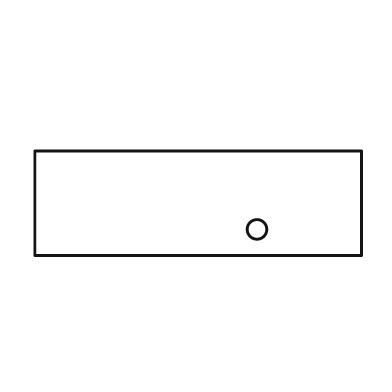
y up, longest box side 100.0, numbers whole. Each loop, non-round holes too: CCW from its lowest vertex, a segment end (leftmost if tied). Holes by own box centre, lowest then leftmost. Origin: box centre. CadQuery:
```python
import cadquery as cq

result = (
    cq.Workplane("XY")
    .moveTo(-50.0, -16.0)
    .lineTo(50.0, -16.0)
    .lineTo(50.0, 16.0)
    .lineTo(-50.0, 16.0)
    .close()
    .moveTo(18.0, -8.0)
    .circle(3.0)
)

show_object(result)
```